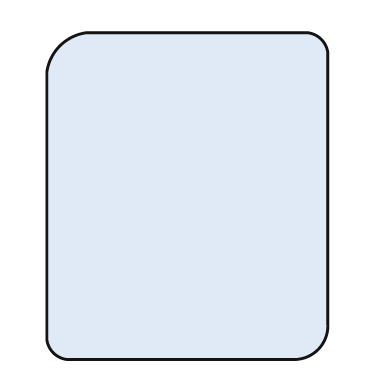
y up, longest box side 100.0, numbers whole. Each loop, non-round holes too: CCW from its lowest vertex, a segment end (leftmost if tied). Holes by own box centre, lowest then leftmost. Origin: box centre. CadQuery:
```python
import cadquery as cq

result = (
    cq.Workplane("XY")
    .moveTo(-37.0, -50.0)
    .lineTo(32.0, -50.0)
    .threePointArc((40.0, -47.0), (43.0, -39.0))
    .lineTo(43.0, 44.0)
    .threePointArc((41.0, 48.0), (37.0, 50.0))
    .lineTo(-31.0, 50.0)
    .threePointArc((-39.0, 46.0), (-43.0, 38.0))
    .lineTo(-43.0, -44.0)
    .threePointArc((-41.0, -48.0), (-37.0, -50.0))
    .close()
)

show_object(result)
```